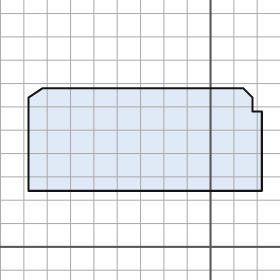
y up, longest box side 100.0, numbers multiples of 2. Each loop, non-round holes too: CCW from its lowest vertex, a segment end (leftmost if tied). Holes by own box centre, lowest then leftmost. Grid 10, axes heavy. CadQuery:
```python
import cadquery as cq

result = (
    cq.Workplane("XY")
    .moveTo(-78.0, 24.0)
    .lineTo(22.0, 24.0)
    .lineTo(22.0, 58.0)
    .lineTo(18.0, 58.0)
    .lineTo(18.0, 64.0)
    .lineTo(14.0, 68.0)
    .lineTo(-72.0, 68.0)
    .lineTo(-78.0, 64.0)
    .close()
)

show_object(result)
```